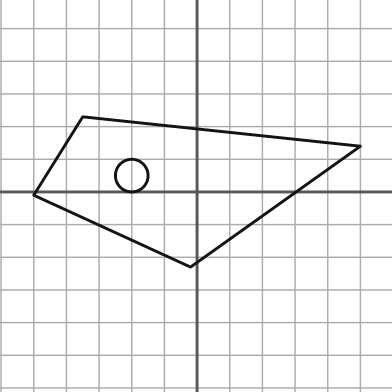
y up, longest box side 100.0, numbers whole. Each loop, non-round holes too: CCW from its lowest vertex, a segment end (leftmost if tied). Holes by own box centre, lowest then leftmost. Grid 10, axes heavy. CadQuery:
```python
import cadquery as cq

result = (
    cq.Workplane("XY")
    .moveTo(-2.0, -23.0)
    .lineTo(50.0, 14.0)
    .lineTo(-35.0, 23.0)
    .lineTo(-50.0, -1.0)
    .close()
    .moveTo(-20.0, 5.0)
    .circle(5.0)
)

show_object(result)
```